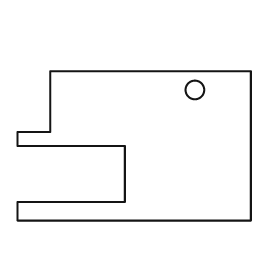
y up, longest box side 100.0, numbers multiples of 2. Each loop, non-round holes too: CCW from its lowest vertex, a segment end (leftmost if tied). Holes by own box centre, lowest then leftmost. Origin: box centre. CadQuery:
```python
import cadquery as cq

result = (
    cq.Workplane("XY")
    .moveTo(-50.0, -32.0)
    .lineTo(50.0, -32.0)
    .lineTo(50.0, 32.0)
    .lineTo(-36.0, 32.0)
    .lineTo(-36.0, 6.0)
    .lineTo(-50.0, 6.0)
    .lineTo(-50.0, 0.0)
    .lineTo(-4.0, 0.0)
    .lineTo(-4.0, -24.0)
    .lineTo(-50.0, -24.0)
    .close()
    .moveTo(26.0, 24.0)
    .circle(4.0)
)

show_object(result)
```